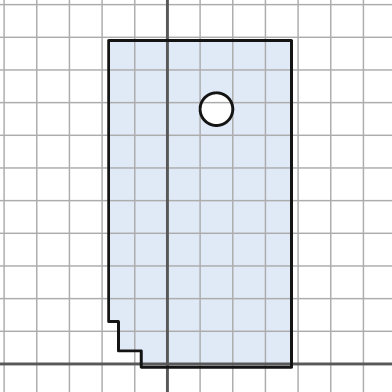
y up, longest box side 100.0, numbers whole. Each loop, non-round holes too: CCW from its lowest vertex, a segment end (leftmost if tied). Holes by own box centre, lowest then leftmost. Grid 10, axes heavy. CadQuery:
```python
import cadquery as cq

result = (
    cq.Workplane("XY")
    .moveTo(-8.0, -1.0)
    .lineTo(38.0, -1.0)
    .lineTo(38.0, 99.0)
    .lineTo(-18.0, 99.0)
    .lineTo(-18.0, 13.0)
    .lineTo(-15.0, 13.0)
    .lineTo(-15.0, 4.0)
    .lineTo(-8.0, 4.0)
    .close()
    .moveTo(15.0, 78.0)
    .circle(5.0)
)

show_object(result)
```